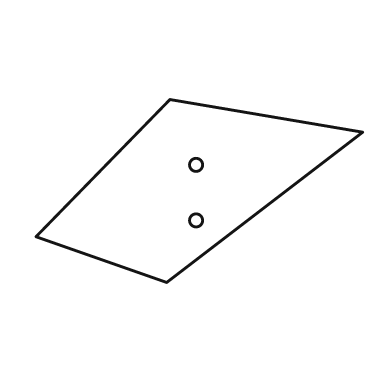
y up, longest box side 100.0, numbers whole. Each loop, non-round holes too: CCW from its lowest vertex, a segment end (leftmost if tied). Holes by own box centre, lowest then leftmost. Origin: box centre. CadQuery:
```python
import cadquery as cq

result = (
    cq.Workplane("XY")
    .moveTo(-10.0, -28.0)
    .lineTo(50.0, 18.0)
    .lineTo(-9.0, 28.0)
    .lineTo(-50.0, -14.0)
    .close()
    .moveTo(-1.0, -9.0)
    .circle(2.0)
    .moveTo(-1.0, 8.0)
    .circle(2.0)
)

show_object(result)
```